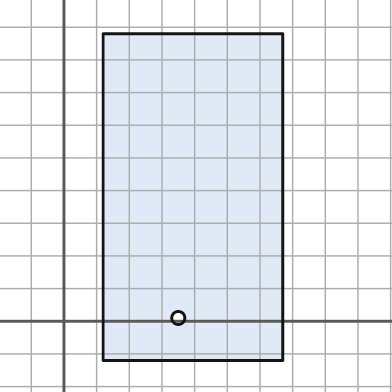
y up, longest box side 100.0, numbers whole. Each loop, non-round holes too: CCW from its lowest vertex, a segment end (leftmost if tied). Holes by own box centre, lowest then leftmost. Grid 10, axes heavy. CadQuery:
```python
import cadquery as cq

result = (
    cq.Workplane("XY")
    .moveTo(12.0, -12.0)
    .lineTo(67.0, -12.0)
    .lineTo(67.0, 88.0)
    .lineTo(12.0, 88.0)
    .close()
    .moveTo(35.0, 1.0)
    .circle(2.0)
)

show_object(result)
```